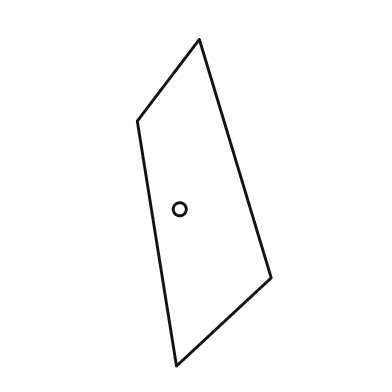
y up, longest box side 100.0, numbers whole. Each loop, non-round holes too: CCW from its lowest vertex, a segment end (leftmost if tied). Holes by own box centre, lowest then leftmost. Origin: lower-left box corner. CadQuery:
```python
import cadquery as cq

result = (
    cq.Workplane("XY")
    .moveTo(12.0, 0.0)
    .lineTo(41.0, 27.0)
    .lineTo(19.0, 100.0)
    .lineTo(0.0, 75.0)
    .close()
    .moveTo(13.0, 48.0)
    .circle(2.0)
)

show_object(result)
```